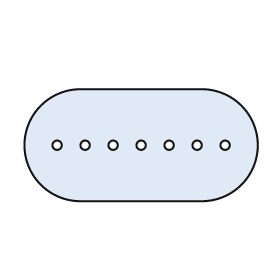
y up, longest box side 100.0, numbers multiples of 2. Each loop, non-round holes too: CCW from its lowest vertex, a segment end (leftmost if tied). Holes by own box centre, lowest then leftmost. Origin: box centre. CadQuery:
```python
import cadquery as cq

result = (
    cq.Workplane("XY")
    .moveTo(-26.0, -24.0)
    .lineTo(26.0, -24.0)
    .threePointArc((50.0, 0.0), (26.0, 24.0))
    .lineTo(-26.0, 24.0)
    .threePointArc((-50.0, 0.0), (-26.0, -24.0))
    .close()
    .moveTo(-36.0, 0.0)
    .circle(2.0)
    .moveTo(-24.0, 0.0)
    .circle(2.0)
    .moveTo(-12.0, 0.0)
    .circle(2.0)
    .moveTo(0.0, 0.0)
    .circle(2.0)
    .moveTo(12.0, 0.0)
    .circle(2.0)
    .moveTo(24.0, 0.0)
    .circle(2.0)
    .moveTo(36.0, 0.0)
    .circle(2.0)
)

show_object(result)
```